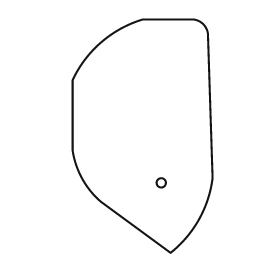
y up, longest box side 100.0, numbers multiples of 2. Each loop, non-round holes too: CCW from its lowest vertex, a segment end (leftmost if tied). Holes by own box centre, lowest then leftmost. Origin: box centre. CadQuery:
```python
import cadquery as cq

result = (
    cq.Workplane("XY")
    .moveTo(12.0, -50.0)
    .threePointArc((24.0, -36.0), (30.0, -18.0))
    .lineTo(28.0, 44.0)
    .threePointArc((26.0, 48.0), (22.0, 50.0))
    .lineTo(0.0, 50.0)
    .threePointArc((-18.0, 40.0), (-30.0, 24.0))
    .lineTo(-30.0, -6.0)
    .threePointArc((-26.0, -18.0), (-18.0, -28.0))
    .close()
    .moveTo(8.0, -20.0)
    .circle(2.0)
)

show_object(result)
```